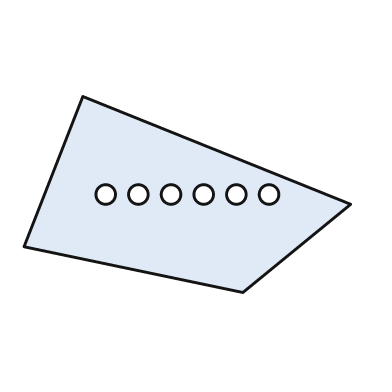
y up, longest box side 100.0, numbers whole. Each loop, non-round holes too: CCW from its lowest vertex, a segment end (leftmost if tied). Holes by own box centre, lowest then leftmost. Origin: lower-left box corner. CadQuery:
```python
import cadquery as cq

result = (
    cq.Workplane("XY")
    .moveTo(67.0, 0.0)
    .lineTo(100.0, 27.0)
    .lineTo(18.0, 60.0)
    .lineTo(0.0, 14.0)
    .close()
    .moveTo(25.0, 30.0)
    .circle(3.0)
    .moveTo(35.0, 30.0)
    .circle(3.0)
    .moveTo(45.0, 30.0)
    .circle(3.0)
    .moveTo(55.0, 30.0)
    .circle(3.0)
    .moveTo(65.0, 30.0)
    .circle(3.0)
    .moveTo(75.0, 30.0)
    .circle(3.0)
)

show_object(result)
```